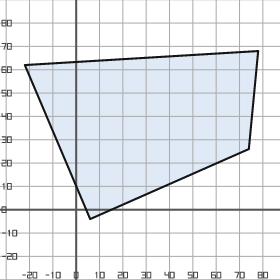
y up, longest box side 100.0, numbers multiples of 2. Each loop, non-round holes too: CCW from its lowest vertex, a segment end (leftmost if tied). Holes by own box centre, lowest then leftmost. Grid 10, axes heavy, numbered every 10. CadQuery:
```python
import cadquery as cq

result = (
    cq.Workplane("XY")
    .moveTo(6.0, -4.0)
    .lineTo(74.0, 26.0)
    .lineTo(78.0, 68.0)
    .lineTo(-22.0, 62.0)
    .close()
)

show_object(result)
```